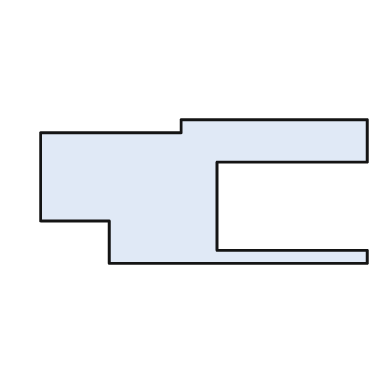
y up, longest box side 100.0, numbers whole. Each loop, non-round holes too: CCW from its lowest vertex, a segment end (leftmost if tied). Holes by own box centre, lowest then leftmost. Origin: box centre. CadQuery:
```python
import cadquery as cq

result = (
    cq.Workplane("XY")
    .moveTo(-29.0, -22.0)
    .lineTo(50.0, -22.0)
    .lineTo(50.0, -18.0)
    .lineTo(4.0, -18.0)
    .lineTo(4.0, 9.0)
    .lineTo(50.0, 9.0)
    .lineTo(50.0, 22.0)
    .lineTo(-7.0, 22.0)
    .lineTo(-7.0, 18.0)
    .lineTo(-50.0, 18.0)
    .lineTo(-50.0, -9.0)
    .lineTo(-29.0, -9.0)
    .close()
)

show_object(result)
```